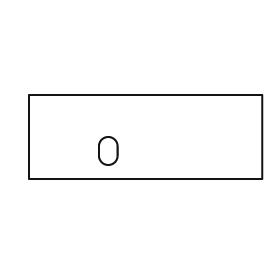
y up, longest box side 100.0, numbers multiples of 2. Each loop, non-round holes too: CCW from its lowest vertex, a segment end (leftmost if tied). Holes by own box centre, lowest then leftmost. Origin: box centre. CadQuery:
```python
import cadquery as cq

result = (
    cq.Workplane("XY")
    .moveTo(-50.0, -18.0)
    .lineTo(50.0, -18.0)
    .lineTo(50.0, 18.0)
    .lineTo(-50.0, 18.0)
    .close()
    .moveTo(-20.0, -8.0)
    .threePointArc((-16.0, -12.0), (-12.0, -8.0))
    .lineTo(-12.0, -4.0)
    .threePointArc((-16.0, 0.0), (-20.0, -4.0))
    .close()
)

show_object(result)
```